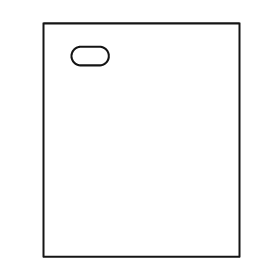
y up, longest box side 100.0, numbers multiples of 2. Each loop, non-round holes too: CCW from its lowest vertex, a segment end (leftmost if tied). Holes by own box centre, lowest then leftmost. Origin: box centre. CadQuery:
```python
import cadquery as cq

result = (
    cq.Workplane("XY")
    .moveTo(-42.0, -50.0)
    .lineTo(42.0, -50.0)
    .lineTo(42.0, 50.0)
    .lineTo(-42.0, 50.0)
    .close()
    .moveTo(-26.0, 32.0)
    .lineTo(-18.0, 32.0)
    .threePointArc((-14.0, 36.0), (-18.0, 40.0))
    .lineTo(-26.0, 40.0)
    .threePointArc((-30.0, 36.0), (-26.0, 32.0))
    .close()
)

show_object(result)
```